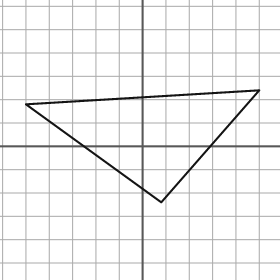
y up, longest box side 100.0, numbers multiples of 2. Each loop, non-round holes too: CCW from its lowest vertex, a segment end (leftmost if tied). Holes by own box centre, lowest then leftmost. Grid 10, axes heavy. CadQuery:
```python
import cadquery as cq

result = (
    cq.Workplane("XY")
    .moveTo(8.0, -24.0)
    .lineTo(50.0, 24.0)
    .lineTo(-50.0, 18.0)
    .close()
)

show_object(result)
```